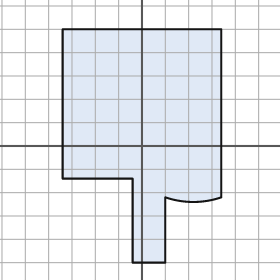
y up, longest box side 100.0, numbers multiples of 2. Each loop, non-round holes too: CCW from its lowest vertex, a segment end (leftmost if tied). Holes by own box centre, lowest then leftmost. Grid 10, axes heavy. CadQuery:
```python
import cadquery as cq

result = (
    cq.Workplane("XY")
    .moveTo(-4.0, -50.0)
    .lineTo(10.0, -50.0)
    .lineTo(10.0, -22.0)
    .threePointArc((22.0, -24.0), (34.0, -22.0))
    .lineTo(34.0, 50.0)
    .lineTo(-34.0, 50.0)
    .lineTo(-34.0, -14.0)
    .lineTo(-4.0, -14.0)
    .close()
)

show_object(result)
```